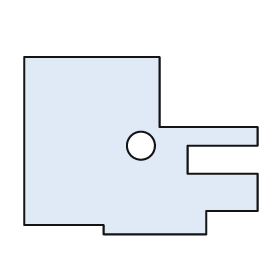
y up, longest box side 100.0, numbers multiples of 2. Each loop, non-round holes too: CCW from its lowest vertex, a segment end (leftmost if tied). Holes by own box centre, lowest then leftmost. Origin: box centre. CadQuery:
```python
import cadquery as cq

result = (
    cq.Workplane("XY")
    .moveTo(-16.0, -38.0)
    .lineTo(28.0, -38.0)
    .lineTo(28.0, -28.0)
    .lineTo(50.0, -28.0)
    .lineTo(50.0, -12.0)
    .lineTo(20.0, -12.0)
    .lineTo(20.0, 0.0)
    .lineTo(50.0, 0.0)
    .lineTo(50.0, 8.0)
    .lineTo(8.0, 8.0)
    .lineTo(8.0, 38.0)
    .lineTo(-50.0, 38.0)
    .lineTo(-50.0, -34.0)
    .lineTo(-16.0, -34.0)
    .close()
    .moveTo(0.0, 0.0)
    .circle(6.0)
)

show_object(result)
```